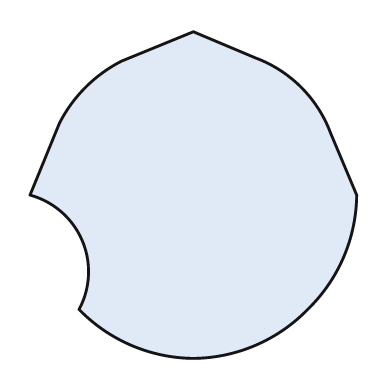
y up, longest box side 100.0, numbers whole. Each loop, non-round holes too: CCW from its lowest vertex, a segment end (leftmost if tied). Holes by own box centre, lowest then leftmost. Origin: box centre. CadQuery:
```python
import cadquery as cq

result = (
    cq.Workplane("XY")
    .moveTo(0.0, -50.0)
    .threePointArc((19.0, -46.0), (35.0, -35.0))
    .threePointArc((46.0, -19.0), (50.0, 0.0))
    .lineTo(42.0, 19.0)
    .threePointArc((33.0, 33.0), (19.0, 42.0))
    .lineTo(0.0, 50.0)
    .lineTo(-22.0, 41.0)
    .threePointArc((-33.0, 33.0), (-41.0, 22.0))
    .lineTo(-50.0, 0.0)
    .threePointArc((-34.0, -14.0), (-35.0, -35.0))
    .threePointArc((-19.0, -46.0), (0.0, -50.0))
    .close()
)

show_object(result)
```